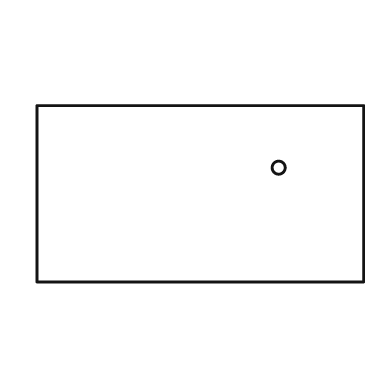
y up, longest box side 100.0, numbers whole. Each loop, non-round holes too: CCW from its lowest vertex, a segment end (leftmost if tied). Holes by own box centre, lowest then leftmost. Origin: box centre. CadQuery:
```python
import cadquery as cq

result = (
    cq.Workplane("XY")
    .moveTo(-50.0, -27.0)
    .lineTo(50.0, -27.0)
    .lineTo(50.0, 27.0)
    .lineTo(-50.0, 27.0)
    .close()
    .moveTo(24.0, 8.0)
    .circle(2.0)
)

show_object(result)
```